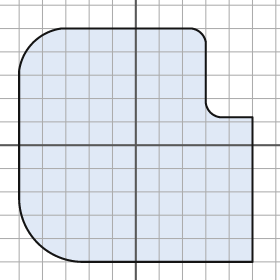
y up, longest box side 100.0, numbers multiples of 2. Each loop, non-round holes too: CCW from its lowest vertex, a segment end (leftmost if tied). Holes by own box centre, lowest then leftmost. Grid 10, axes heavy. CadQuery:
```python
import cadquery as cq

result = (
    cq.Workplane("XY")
    .moveTo(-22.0, -50.0)
    .lineTo(50.0, -50.0)
    .lineTo(50.0, 12.0)
    .lineTo(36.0, 12.0)
    .threePointArc((32.0, 14.0), (30.0, 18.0))
    .lineTo(30.0, 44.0)
    .threePointArc((28.0, 48.0), (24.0, 50.0))
    .lineTo(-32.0, 50.0)
    .threePointArc((-44.0, 44.0), (-50.0, 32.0))
    .lineTo(-50.0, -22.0)
    .threePointArc((-42.0, -42.0), (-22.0, -50.0))
    .close()
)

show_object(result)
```